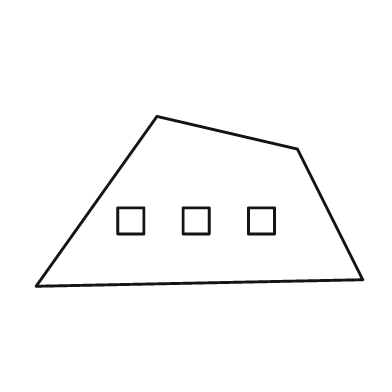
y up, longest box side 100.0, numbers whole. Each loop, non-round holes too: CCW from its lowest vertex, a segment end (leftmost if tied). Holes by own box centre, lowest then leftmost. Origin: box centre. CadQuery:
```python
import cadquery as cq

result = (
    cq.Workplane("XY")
    .moveTo(-50.0, -26.0)
    .lineTo(50.0, -24.0)
    .lineTo(30.0, 16.0)
    .lineTo(-13.0, 26.0)
    .close()
    .moveTo(-25.0, -10.0)
    .lineTo(-17.0, -10.0)
    .lineTo(-17.0, -2.0)
    .lineTo(-25.0, -2.0)
    .close()
    .moveTo(-5.0, -10.0)
    .lineTo(3.0, -10.0)
    .lineTo(3.0, -2.0)
    .lineTo(-5.0, -2.0)
    .close()
    .moveTo(15.0, -10.0)
    .lineTo(23.0, -10.0)
    .lineTo(23.0, -2.0)
    .lineTo(15.0, -2.0)
    .close()
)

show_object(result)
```